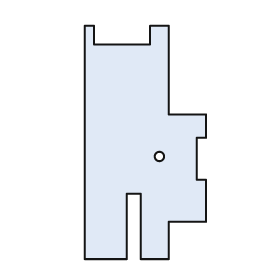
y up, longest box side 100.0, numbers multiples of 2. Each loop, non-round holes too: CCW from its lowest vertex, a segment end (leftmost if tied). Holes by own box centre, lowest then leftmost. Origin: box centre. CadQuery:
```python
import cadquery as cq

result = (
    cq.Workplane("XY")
    .moveTo(-26.0, -50.0)
    .lineTo(-8.0, -50.0)
    .lineTo(-8.0, -22.0)
    .lineTo(-2.0, -22.0)
    .lineTo(-2.0, -50.0)
    .lineTo(10.0, -50.0)
    .lineTo(10.0, -34.0)
    .lineTo(26.0, -34.0)
    .lineTo(26.0, -16.0)
    .lineTo(22.0, -16.0)
    .lineTo(22.0, 2.0)
    .lineTo(26.0, 2.0)
    .lineTo(26.0, 12.0)
    .lineTo(10.0, 12.0)
    .lineTo(10.0, 50.0)
    .lineTo(2.0, 50.0)
    .lineTo(2.0, 42.0)
    .lineTo(-22.0, 42.0)
    .lineTo(-22.0, 50.0)
    .lineTo(-26.0, 50.0)
    .close()
    .moveTo(6.0, -6.0)
    .circle(2.0)
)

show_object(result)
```